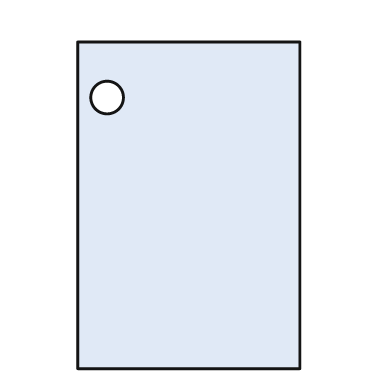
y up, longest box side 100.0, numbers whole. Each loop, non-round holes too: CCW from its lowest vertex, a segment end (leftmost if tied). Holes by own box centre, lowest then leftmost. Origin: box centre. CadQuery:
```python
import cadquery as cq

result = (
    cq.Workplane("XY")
    .moveTo(-34.0, -50.0)
    .lineTo(34.0, -50.0)
    .lineTo(34.0, 50.0)
    .lineTo(-34.0, 50.0)
    .close()
    .moveTo(-25.0, 33.0)
    .circle(5.0)
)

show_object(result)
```